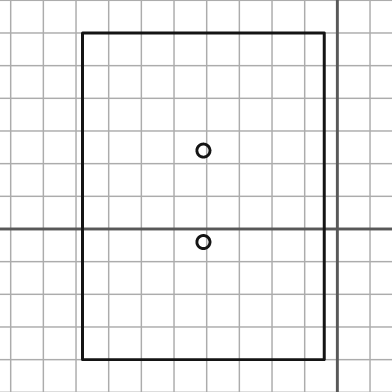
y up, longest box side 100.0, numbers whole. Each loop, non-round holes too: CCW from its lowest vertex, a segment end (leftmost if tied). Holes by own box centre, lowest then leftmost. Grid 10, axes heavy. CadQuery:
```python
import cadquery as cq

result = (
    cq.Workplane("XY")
    .moveTo(-78.0, -40.0)
    .lineTo(-4.0, -40.0)
    .lineTo(-4.0, 60.0)
    .lineTo(-78.0, 60.0)
    .close()
    .moveTo(-41.0, -4.0)
    .circle(2.0)
    .moveTo(-41.0, 24.0)
    .circle(2.0)
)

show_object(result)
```